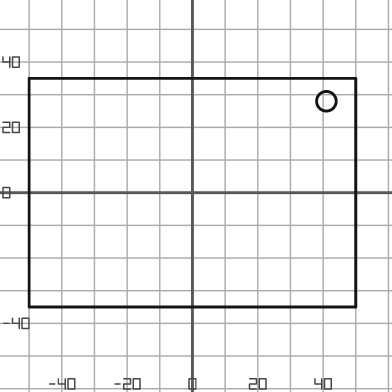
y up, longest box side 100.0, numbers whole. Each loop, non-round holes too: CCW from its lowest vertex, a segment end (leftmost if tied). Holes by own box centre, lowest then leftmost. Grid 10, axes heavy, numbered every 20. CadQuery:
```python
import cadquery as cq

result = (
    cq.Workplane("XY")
    .moveTo(-50.0, -35.0)
    .lineTo(50.0, -35.0)
    .lineTo(50.0, 35.0)
    .lineTo(-50.0, 35.0)
    .close()
    .moveTo(41.0, 28.0)
    .circle(3.0)
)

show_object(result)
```